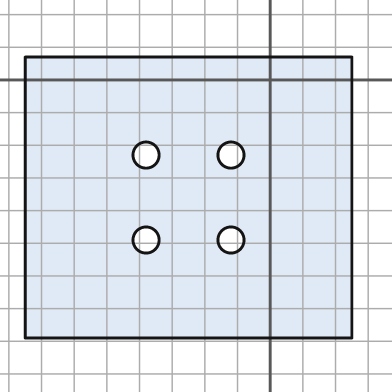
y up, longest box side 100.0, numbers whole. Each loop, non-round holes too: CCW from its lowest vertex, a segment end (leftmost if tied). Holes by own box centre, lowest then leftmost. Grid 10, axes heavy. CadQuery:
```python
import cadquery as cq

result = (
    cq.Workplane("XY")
    .moveTo(-75.0, -79.0)
    .lineTo(25.0, -79.0)
    .lineTo(25.0, 7.0)
    .lineTo(-75.0, 7.0)
    .close()
    .moveTo(-38.0, -49.0)
    .circle(4.0)
    .moveTo(-12.0, -49.0)
    .circle(4.0)
    .moveTo(-38.0, -23.0)
    .circle(4.0)
    .moveTo(-12.0, -23.0)
    .circle(4.0)
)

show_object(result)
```